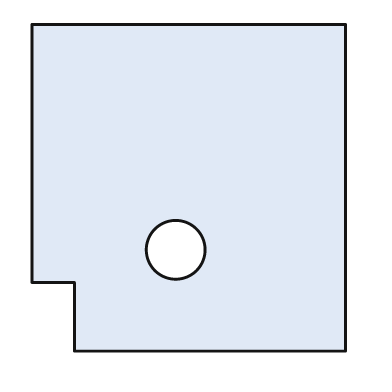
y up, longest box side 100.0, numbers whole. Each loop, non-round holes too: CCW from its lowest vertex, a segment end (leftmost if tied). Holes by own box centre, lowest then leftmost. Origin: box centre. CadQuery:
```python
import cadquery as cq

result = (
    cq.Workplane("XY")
    .moveTo(-35.0, -50.0)
    .lineTo(48.0, -50.0)
    .lineTo(48.0, 50.0)
    .lineTo(-48.0, 50.0)
    .lineTo(-48.0, -29.0)
    .lineTo(-35.0, -29.0)
    .close()
    .moveTo(-4.0, -19.0)
    .circle(9.0)
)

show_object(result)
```